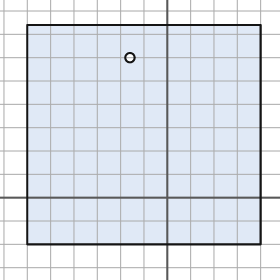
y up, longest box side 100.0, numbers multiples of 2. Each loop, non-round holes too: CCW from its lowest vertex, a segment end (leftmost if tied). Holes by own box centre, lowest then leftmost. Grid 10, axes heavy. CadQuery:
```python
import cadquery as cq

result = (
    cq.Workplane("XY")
    .moveTo(-60.0, -20.0)
    .lineTo(40.0, -20.0)
    .lineTo(40.0, 74.0)
    .lineTo(-60.0, 74.0)
    .close()
    .moveTo(-16.0, 60.0)
    .circle(2.0)
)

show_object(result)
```